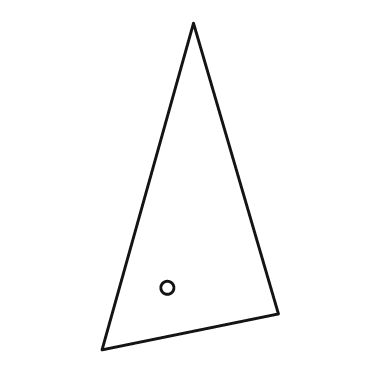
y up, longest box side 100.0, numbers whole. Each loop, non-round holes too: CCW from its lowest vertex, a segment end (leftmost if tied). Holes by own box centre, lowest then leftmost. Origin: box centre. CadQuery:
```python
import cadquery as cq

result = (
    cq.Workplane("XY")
    .moveTo(-27.0, -50.0)
    .lineTo(27.0, -39.0)
    .lineTo(1.0, 50.0)
    .close()
    .moveTo(-7.0, -31.0)
    .circle(2.0)
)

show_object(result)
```